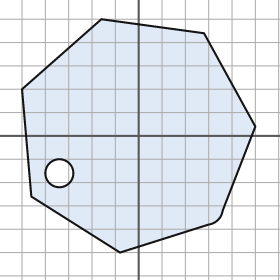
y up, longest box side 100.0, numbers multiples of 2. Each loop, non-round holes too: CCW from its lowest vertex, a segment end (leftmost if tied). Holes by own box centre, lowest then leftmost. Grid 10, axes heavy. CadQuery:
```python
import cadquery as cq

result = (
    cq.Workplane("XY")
    .moveTo(-8.0, -50.0)
    .lineTo(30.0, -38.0)
    .threePointArc((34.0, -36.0), (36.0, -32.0))
    .lineTo(50.0, 4.0)
    .lineTo(28.0, 44.0)
    .lineTo(-16.0, 50.0)
    .lineTo(-50.0, 20.0)
    .lineTo(-46.0, -26.0)
    .close()
    .moveTo(-34.0, -16.0)
    .circle(6.0)
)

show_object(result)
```